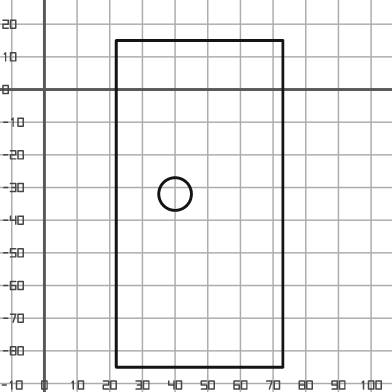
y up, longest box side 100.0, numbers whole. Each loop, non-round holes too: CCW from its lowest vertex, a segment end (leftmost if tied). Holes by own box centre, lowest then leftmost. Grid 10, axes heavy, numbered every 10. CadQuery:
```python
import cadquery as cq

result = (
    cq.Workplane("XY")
    .moveTo(22.0, -85.0)
    .lineTo(73.0, -85.0)
    .lineTo(73.0, 15.0)
    .lineTo(22.0, 15.0)
    .close()
    .moveTo(40.0, -32.0)
    .circle(5.0)
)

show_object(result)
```